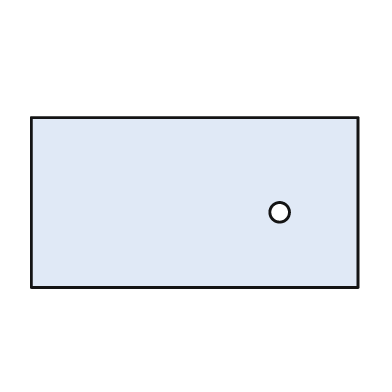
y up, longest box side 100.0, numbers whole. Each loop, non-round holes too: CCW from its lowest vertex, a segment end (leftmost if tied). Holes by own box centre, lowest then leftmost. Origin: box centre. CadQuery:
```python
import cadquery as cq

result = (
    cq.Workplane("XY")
    .moveTo(-50.0, -26.0)
    .lineTo(50.0, -26.0)
    .lineTo(50.0, 26.0)
    .lineTo(-50.0, 26.0)
    .close()
    .moveTo(26.0, -3.0)
    .circle(3.0)
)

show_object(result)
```